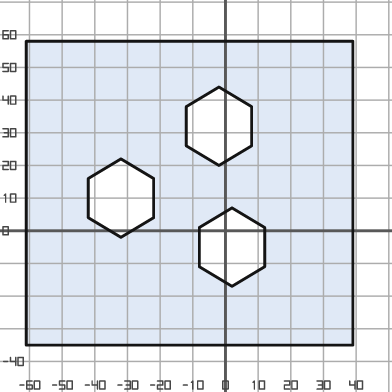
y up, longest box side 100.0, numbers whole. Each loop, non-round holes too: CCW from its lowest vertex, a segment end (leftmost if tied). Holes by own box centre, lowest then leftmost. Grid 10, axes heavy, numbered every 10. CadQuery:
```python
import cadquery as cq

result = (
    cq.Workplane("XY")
    .moveTo(-61.0, -35.0)
    .lineTo(39.0, -35.0)
    .lineTo(39.0, 58.0)
    .lineTo(-61.0, 58.0)
    .close()
    .moveTo(2.0, -17.0)
    .lineTo(12.0, -11.0)
    .lineTo(12.0, 1.0)
    .lineTo(2.0, 7.0)
    .lineTo(-8.0, 1.0)
    .lineTo(-8.0, -11.0)
    .close()
    .moveTo(-32.0, -2.0)
    .lineTo(-22.0, 4.0)
    .lineTo(-22.0, 16.0)
    .lineTo(-32.0, 22.0)
    .lineTo(-42.0, 16.0)
    .lineTo(-42.0, 4.0)
    .close()
    .moveTo(-2.0, 20.0)
    .lineTo(8.0, 26.0)
    .lineTo(8.0, 38.0)
    .lineTo(-2.0, 44.0)
    .lineTo(-12.0, 38.0)
    .lineTo(-12.0, 26.0)
    .close()
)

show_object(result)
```